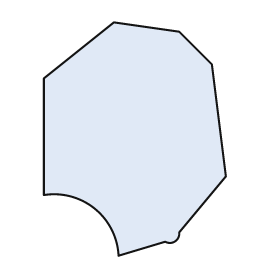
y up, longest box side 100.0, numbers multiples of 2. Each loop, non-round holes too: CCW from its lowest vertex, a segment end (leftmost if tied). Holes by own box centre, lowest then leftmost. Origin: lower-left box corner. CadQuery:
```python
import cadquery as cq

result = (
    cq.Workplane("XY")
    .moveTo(32.0, 0.0)
    .lineTo(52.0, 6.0)
    .threePointArc((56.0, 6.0), (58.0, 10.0))
    .lineTo(78.0, 34.0)
    .lineTo(72.0, 82.0)
    .lineTo(58.0, 96.0)
    .lineTo(30.0, 100.0)
    .lineTo(0.0, 76.0)
    .lineTo(0.0, 26.0)
    .threePointArc((22.0, 20.0), (32.0, 0.0))
    .close()
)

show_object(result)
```